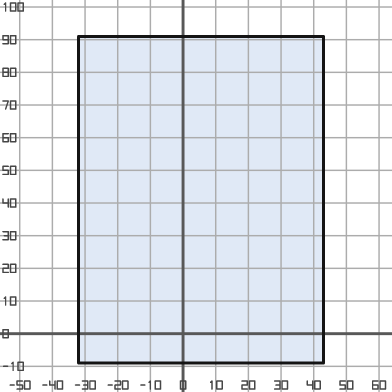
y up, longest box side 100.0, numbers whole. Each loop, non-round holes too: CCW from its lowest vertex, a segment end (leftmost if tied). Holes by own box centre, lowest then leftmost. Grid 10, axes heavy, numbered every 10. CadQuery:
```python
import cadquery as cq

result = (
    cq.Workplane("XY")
    .moveTo(-32.0, -9.0)
    .lineTo(43.0, -9.0)
    .lineTo(43.0, 91.0)
    .lineTo(-32.0, 91.0)
    .close()
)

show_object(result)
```